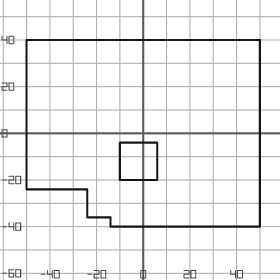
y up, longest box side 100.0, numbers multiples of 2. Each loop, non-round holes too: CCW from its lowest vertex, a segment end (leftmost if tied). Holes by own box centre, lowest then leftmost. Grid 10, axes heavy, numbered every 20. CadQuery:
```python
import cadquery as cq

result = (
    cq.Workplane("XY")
    .moveTo(-14.0, -40.0)
    .lineTo(50.0, -40.0)
    .lineTo(50.0, 40.0)
    .lineTo(-50.0, 40.0)
    .lineTo(-50.0, -24.0)
    .lineTo(-24.0, -24.0)
    .lineTo(-24.0, -36.0)
    .lineTo(-14.0, -36.0)
    .close()
    .moveTo(-10.0, -20.0)
    .lineTo(6.0, -20.0)
    .lineTo(6.0, -4.0)
    .lineTo(-10.0, -4.0)
    .close()
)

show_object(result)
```